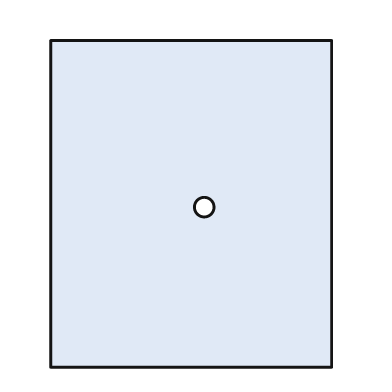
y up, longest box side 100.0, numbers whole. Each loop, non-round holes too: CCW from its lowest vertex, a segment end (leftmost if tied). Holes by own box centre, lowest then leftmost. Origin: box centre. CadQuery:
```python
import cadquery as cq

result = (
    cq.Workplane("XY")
    .moveTo(-43.0, -50.0)
    .lineTo(43.0, -50.0)
    .lineTo(43.0, 50.0)
    .lineTo(-43.0, 50.0)
    .close()
    .moveTo(4.0, -1.0)
    .circle(3.0)
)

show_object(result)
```